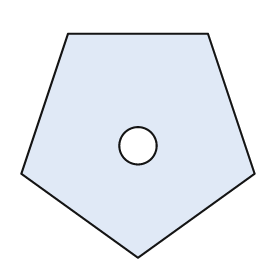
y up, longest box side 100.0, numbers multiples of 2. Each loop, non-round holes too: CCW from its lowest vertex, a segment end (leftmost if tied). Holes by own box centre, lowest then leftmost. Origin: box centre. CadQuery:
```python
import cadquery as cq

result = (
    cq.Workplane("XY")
    .moveTo(0.0, -48.0)
    .lineTo(50.0, -12.0)
    .lineTo(30.0, 48.0)
    .lineTo(-30.0, 48.0)
    .lineTo(-50.0, -12.0)
    .close()
    .moveTo(0.0, 0.0)
    .circle(8.0)
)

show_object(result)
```